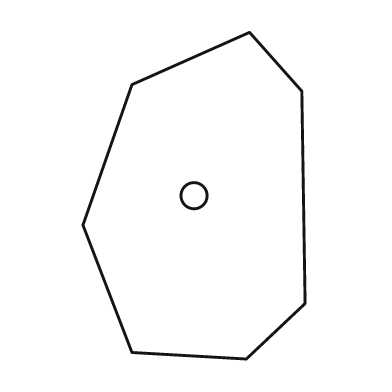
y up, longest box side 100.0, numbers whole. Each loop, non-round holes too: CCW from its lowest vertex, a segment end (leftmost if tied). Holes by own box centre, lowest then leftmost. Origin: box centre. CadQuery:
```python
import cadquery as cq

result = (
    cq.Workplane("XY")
    .moveTo(16.0, -50.0)
    .lineTo(34.0, -33.0)
    .lineTo(33.0, 32.0)
    .lineTo(17.0, 50.0)
    .lineTo(-19.0, 34.0)
    .lineTo(-34.0, -9.0)
    .lineTo(-19.0, -48.0)
    .close()
    .moveTo(0.0, 0.0)
    .circle(4.0)
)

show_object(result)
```